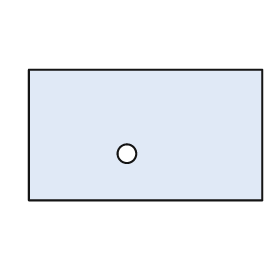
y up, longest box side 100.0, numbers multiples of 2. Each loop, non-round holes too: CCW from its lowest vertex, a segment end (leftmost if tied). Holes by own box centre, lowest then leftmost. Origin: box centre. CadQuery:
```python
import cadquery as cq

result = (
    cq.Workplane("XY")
    .moveTo(-50.0, -28.0)
    .lineTo(50.0, -28.0)
    .lineTo(50.0, 28.0)
    .lineTo(-50.0, 28.0)
    .close()
    .moveTo(-8.0, -8.0)
    .circle(4.0)
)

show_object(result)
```